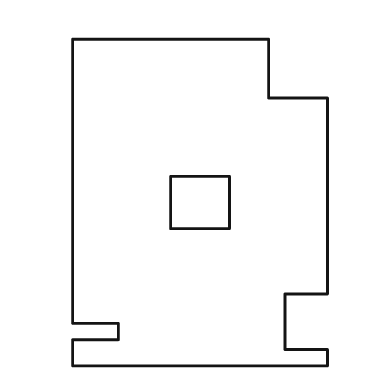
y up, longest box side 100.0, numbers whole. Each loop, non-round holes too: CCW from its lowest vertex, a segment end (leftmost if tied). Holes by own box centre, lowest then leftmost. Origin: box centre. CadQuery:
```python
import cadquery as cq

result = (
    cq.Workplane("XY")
    .moveTo(-39.0, -50.0)
    .lineTo(39.0, -50.0)
    .lineTo(39.0, -45.0)
    .lineTo(26.0, -45.0)
    .lineTo(26.0, -28.0)
    .lineTo(39.0, -28.0)
    .lineTo(39.0, 32.0)
    .lineTo(21.0, 32.0)
    .lineTo(21.0, 50.0)
    .lineTo(-39.0, 50.0)
    .lineTo(-39.0, -37.0)
    .lineTo(-25.0, -37.0)
    .lineTo(-25.0, -42.0)
    .lineTo(-39.0, -42.0)
    .close()
    .moveTo(-9.0, -8.0)
    .lineTo(9.0, -8.0)
    .lineTo(9.0, 8.0)
    .lineTo(-9.0, 8.0)
    .close()
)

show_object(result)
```